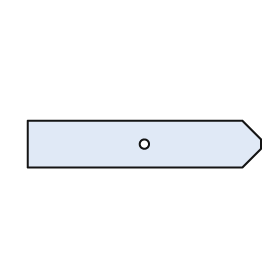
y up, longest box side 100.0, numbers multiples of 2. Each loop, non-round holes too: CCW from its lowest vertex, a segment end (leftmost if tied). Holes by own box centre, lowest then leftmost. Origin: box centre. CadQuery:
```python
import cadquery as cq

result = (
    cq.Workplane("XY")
    .moveTo(-50.0, -10.0)
    .lineTo(42.0, -10.0)
    .lineTo(50.0, -2.0)
    .lineTo(50.0, 2.0)
    .lineTo(42.0, 10.0)
    .lineTo(-50.0, 10.0)
    .close()
    .moveTo(0.0, 0.0)
    .circle(2.0)
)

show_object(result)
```